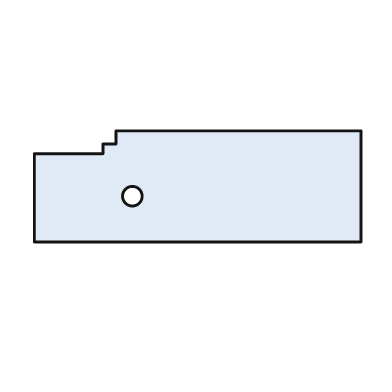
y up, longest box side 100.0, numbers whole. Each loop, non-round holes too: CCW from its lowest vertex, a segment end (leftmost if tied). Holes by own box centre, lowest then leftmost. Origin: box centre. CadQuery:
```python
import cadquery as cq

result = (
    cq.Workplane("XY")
    .moveTo(-50.0, -17.0)
    .lineTo(50.0, -17.0)
    .lineTo(50.0, 17.0)
    .lineTo(-25.0, 17.0)
    .lineTo(-25.0, 13.0)
    .lineTo(-29.0, 13.0)
    .lineTo(-29.0, 10.0)
    .lineTo(-50.0, 10.0)
    .close()
    .moveTo(-20.0, -3.0)
    .circle(3.0)
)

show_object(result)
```